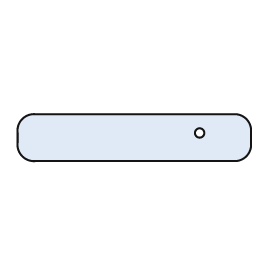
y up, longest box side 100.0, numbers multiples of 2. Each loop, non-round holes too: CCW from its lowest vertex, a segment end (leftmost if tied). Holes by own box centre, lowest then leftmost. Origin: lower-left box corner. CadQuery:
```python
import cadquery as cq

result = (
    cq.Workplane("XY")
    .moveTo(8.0, 0.0)
    .lineTo(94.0, 0.0)
    .threePointArc((98.0, 2.0), (100.0, 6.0))
    .lineTo(100.0, 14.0)
    .threePointArc((98.0, 18.0), (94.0, 20.0))
    .lineTo(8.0, 20.0)
    .threePointArc((2.0, 18.0), (0.0, 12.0))
    .lineTo(0.0, 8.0)
    .threePointArc((2.0, 2.0), (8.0, 0.0))
    .close()
    .moveTo(78.0, 12.0)
    .circle(2.0)
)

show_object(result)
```